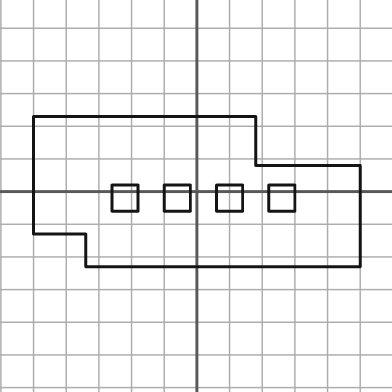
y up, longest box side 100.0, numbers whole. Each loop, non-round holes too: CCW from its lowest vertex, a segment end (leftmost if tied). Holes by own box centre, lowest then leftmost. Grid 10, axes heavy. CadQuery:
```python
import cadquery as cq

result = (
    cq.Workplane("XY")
    .moveTo(-34.0, -23.0)
    .lineTo(50.0, -23.0)
    .lineTo(50.0, 8.0)
    .lineTo(18.0, 8.0)
    .lineTo(18.0, 23.0)
    .lineTo(-50.0, 23.0)
    .lineTo(-50.0, -13.0)
    .lineTo(-34.0, -13.0)
    .close()
    .moveTo(-26.0, -6.0)
    .lineTo(-18.0, -6.0)
    .lineTo(-18.0, 2.0)
    .lineTo(-26.0, 2.0)
    .close()
    .moveTo(-10.0, -6.0)
    .lineTo(-2.0, -6.0)
    .lineTo(-2.0, 2.0)
    .lineTo(-10.0, 2.0)
    .close()
    .moveTo(6.0, -6.0)
    .lineTo(14.0, -6.0)
    .lineTo(14.0, 2.0)
    .lineTo(6.0, 2.0)
    .close()
    .moveTo(22.0, -6.0)
    .lineTo(30.0, -6.0)
    .lineTo(30.0, 2.0)
    .lineTo(22.0, 2.0)
    .close()
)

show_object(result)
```